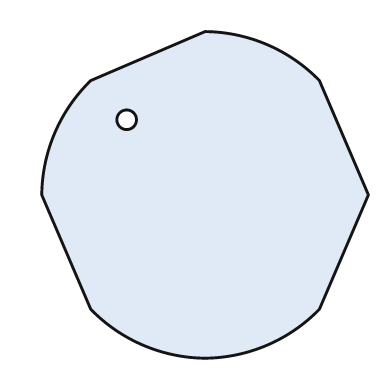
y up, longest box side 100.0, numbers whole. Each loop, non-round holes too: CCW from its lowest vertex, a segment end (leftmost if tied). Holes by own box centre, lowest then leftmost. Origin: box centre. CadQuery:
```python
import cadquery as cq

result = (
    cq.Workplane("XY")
    .moveTo(0.0, -50.0)
    .threePointArc((19.0, -46.0), (35.0, -35.0))
    .lineTo(50.0, 0.0)
    .lineTo(35.0, 35.0)
    .threePointArc((19.0, 46.0), (0.0, 50.0))
    .lineTo(-35.0, 35.0)
    .threePointArc((-46.0, 19.0), (-50.0, 0.0))
    .lineTo(-35.0, -35.0)
    .threePointArc((-19.0, -46.0), (0.0, -50.0))
    .close()
    .moveTo(-24.0, 23.0)
    .circle(3.0)
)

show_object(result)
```